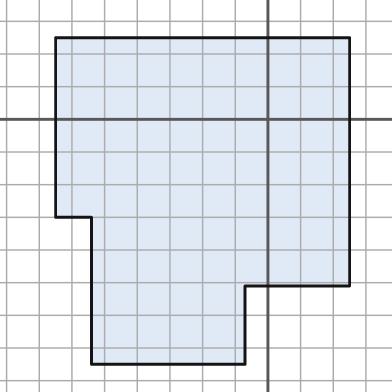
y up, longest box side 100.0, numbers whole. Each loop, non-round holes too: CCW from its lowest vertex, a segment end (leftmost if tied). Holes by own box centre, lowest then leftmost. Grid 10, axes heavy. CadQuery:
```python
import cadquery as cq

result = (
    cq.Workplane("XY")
    .moveTo(-54.0, -75.0)
    .lineTo(-7.0, -75.0)
    .lineTo(-7.0, -51.0)
    .lineTo(25.0, -51.0)
    .lineTo(25.0, 25.0)
    .lineTo(-65.0, 25.0)
    .lineTo(-65.0, -30.0)
    .lineTo(-54.0, -30.0)
    .close()
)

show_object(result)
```